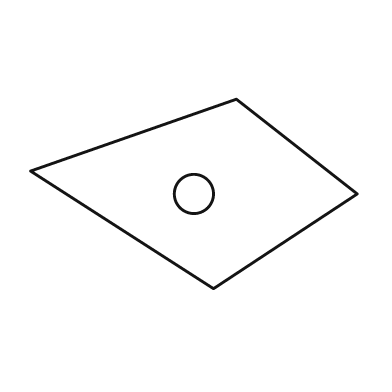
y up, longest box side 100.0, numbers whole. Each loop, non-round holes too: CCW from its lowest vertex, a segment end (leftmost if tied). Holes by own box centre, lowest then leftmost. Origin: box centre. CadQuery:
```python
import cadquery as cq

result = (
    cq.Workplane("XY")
    .moveTo(6.0, -29.0)
    .lineTo(50.0, 0.0)
    .lineTo(13.0, 29.0)
    .lineTo(-50.0, 7.0)
    .close()
    .moveTo(0.0, 0.0)
    .circle(6.0)
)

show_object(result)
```